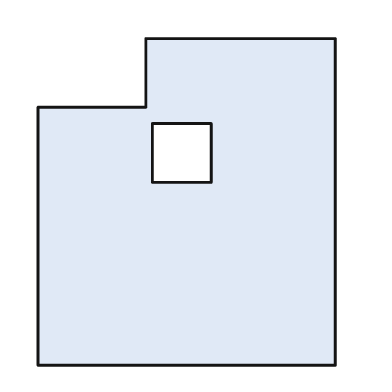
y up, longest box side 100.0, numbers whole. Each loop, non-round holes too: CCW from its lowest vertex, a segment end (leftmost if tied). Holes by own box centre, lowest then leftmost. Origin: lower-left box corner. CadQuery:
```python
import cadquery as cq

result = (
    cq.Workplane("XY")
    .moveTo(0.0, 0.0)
    .lineTo(91.0, 0.0)
    .lineTo(91.0, 100.0)
    .lineTo(33.0, 100.0)
    .lineTo(33.0, 79.0)
    .lineTo(0.0, 79.0)
    .close()
    .moveTo(35.0, 56.0)
    .lineTo(53.0, 56.0)
    .lineTo(53.0, 74.0)
    .lineTo(35.0, 74.0)
    .close()
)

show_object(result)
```